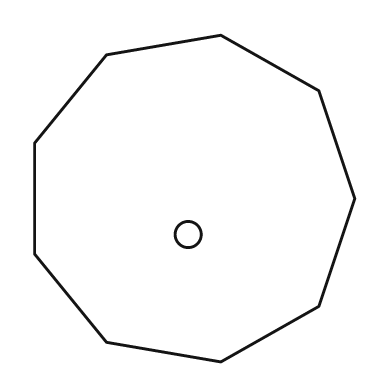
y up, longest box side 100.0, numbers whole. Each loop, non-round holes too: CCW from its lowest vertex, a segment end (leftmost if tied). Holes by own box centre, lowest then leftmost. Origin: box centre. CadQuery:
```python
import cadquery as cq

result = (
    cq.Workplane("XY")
    .moveTo(8.0, -50.0)
    .lineTo(38.0, -33.0)
    .lineTo(49.0, 0.0)
    .lineTo(38.0, 33.0)
    .lineTo(8.0, 50.0)
    .lineTo(-27.0, 44.0)
    .lineTo(-49.0, 17.0)
    .lineTo(-49.0, -17.0)
    .lineTo(-27.0, -44.0)
    .close()
    .moveTo(-2.0, -11.0)
    .circle(4.0)
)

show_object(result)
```